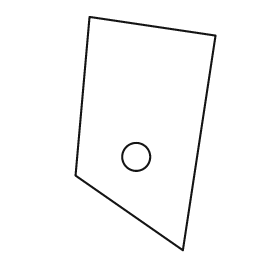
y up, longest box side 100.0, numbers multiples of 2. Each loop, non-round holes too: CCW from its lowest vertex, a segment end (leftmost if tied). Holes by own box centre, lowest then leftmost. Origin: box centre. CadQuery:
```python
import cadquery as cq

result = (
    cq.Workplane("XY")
    .moveTo(16.0, -50.0)
    .lineTo(30.0, 42.0)
    .lineTo(-24.0, 50.0)
    .lineTo(-30.0, -18.0)
    .close()
    .moveTo(-4.0, -10.0)
    .circle(6.0)
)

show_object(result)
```